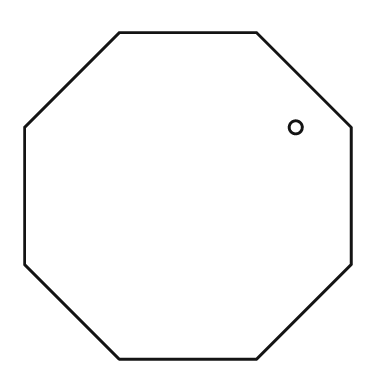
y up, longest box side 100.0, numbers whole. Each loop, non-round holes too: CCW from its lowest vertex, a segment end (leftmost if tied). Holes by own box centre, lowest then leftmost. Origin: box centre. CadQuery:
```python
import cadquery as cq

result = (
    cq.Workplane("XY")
    .moveTo(-21.0, -50.0)
    .lineTo(21.0, -50.0)
    .lineTo(50.0, -21.0)
    .lineTo(50.0, 21.0)
    .lineTo(21.0, 50.0)
    .lineTo(-21.0, 50.0)
    .lineTo(-50.0, 21.0)
    .lineTo(-50.0, -21.0)
    .close()
    .moveTo(33.0, 21.0)
    .circle(2.0)
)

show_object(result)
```